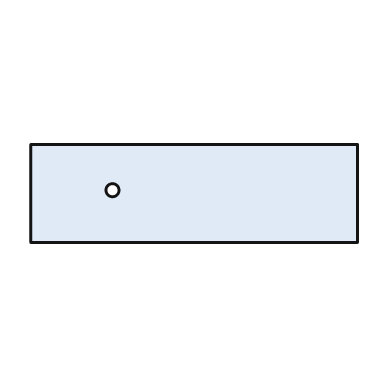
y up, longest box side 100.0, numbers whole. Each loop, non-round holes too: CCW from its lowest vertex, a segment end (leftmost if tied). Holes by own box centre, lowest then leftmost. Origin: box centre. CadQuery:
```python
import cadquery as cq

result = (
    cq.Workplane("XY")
    .moveTo(-50.0, -15.0)
    .lineTo(50.0, -15.0)
    .lineTo(50.0, 15.0)
    .lineTo(-50.0, 15.0)
    .close()
    .moveTo(-25.0, 1.0)
    .circle(2.0)
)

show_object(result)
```